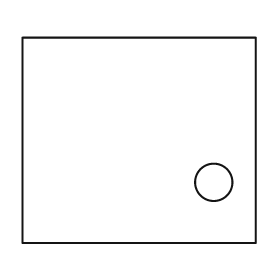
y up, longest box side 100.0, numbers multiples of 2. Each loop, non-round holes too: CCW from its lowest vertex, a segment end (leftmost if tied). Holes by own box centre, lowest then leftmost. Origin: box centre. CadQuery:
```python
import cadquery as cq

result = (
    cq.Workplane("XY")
    .moveTo(-50.0, -44.0)
    .lineTo(50.0, -44.0)
    .lineTo(50.0, 44.0)
    .lineTo(-50.0, 44.0)
    .close()
    .moveTo(32.0, -18.0)
    .circle(8.0)
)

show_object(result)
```